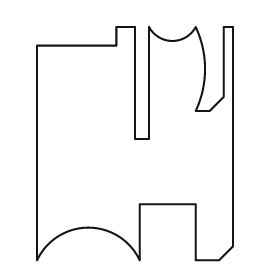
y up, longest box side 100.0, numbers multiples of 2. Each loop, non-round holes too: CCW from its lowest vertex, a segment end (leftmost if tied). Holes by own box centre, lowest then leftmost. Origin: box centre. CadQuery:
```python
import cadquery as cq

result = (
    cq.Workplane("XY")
    .moveTo(-42.0, -50.0)
    .threePointArc((-20.0, -36.0), (2.0, -50.0))
    .lineTo(2.0, -26.0)
    .lineTo(26.0, -26.0)
    .lineTo(26.0, -50.0)
    .lineTo(36.0, -50.0)
    .lineTo(42.0, -44.0)
    .lineTo(42.0, 50.0)
    .lineTo(38.0, 50.0)
    .lineTo(38.0, 20.0)
    .lineTo(32.0, 14.0)
    .lineTo(26.0, 14.0)
    .threePointArc((30.0, 32.0), (26.0, 50.0))
    .threePointArc((16.0, 44.0), (6.0, 50.0))
    .lineTo(6.0, 2.0)
    .lineTo(0.0, 2.0)
    .lineTo(0.0, 50.0)
    .lineTo(-8.0, 50.0)
    .lineTo(-8.0, 42.0)
    .lineTo(-42.0, 42.0)
    .close()
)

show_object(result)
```